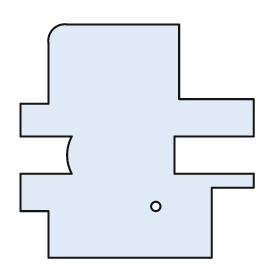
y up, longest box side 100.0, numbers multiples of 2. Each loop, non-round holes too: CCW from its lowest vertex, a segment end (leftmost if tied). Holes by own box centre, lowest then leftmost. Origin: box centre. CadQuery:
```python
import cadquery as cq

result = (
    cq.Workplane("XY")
    .moveTo(-38.0, -50.0)
    .lineTo(32.0, -50.0)
    .lineTo(32.0, -20.0)
    .lineTo(50.0, -20.0)
    .lineTo(50.0, -14.0)
    .lineTo(16.0, -14.0)
    .lineTo(16.0, 2.0)
    .lineTo(50.0, 2.0)
    .lineTo(50.0, 18.0)
    .lineTo(18.0, 18.0)
    .lineTo(18.0, 50.0)
    .lineTo(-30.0, 50.0)
    .threePointArc((-36.0, 48.0), (-38.0, 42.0))
    .lineTo(-38.0, 16.0)
    .lineTo(-50.0, 16.0)
    .lineTo(-50.0, 2.0)
    .lineTo(-28.0, 2.0)
    .threePointArc((-30.0, -6.0), (-28.0, -14.0))
    .lineTo(-50.0, -14.0)
    .lineTo(-50.0, -30.0)
    .lineTo(-38.0, -30.0)
    .close()
    .moveTo(8.0, -28.0)
    .circle(2.0)
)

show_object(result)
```